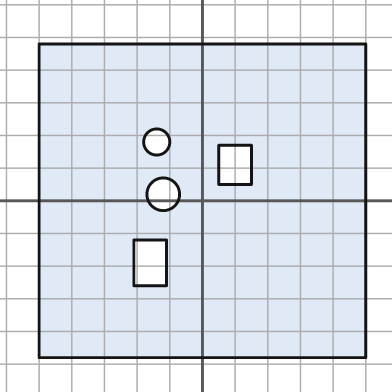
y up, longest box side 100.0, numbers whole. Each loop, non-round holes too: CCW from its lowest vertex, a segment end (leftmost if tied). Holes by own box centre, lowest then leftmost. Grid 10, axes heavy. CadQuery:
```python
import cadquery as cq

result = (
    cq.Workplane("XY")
    .moveTo(-50.0, -48.0)
    .lineTo(50.0, -48.0)
    .lineTo(50.0, 48.0)
    .lineTo(-50.0, 48.0)
    .close()
    .moveTo(-21.0, -26.0)
    .lineTo(-11.0, -26.0)
    .lineTo(-11.0, -12.0)
    .lineTo(-21.0, -12.0)
    .close()
    .moveTo(-12.0, 2.0)
    .circle(5.0)
    .moveTo(5.0, 5.0)
    .lineTo(15.0, 5.0)
    .lineTo(15.0, 17.0)
    .lineTo(5.0, 17.0)
    .close()
    .moveTo(-14.0, 18.0)
    .circle(4.0)
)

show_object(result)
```